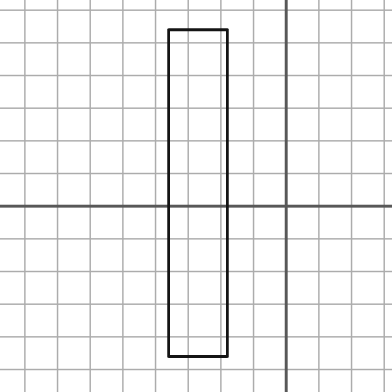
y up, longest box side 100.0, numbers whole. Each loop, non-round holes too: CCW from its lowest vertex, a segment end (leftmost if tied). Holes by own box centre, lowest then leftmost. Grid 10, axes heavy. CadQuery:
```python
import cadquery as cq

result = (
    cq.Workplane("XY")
    .moveTo(-36.0, -46.0)
    .lineTo(-18.0, -46.0)
    .lineTo(-18.0, 54.0)
    .lineTo(-36.0, 54.0)
    .close()
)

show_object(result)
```